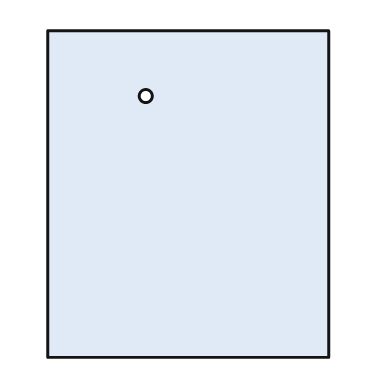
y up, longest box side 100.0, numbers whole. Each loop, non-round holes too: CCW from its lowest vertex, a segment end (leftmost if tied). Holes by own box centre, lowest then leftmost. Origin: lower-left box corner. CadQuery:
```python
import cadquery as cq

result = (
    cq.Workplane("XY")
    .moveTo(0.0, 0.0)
    .lineTo(86.0, 0.0)
    .lineTo(86.0, 100.0)
    .lineTo(0.0, 100.0)
    .close()
    .moveTo(30.0, 80.0)
    .circle(2.0)
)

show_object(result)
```